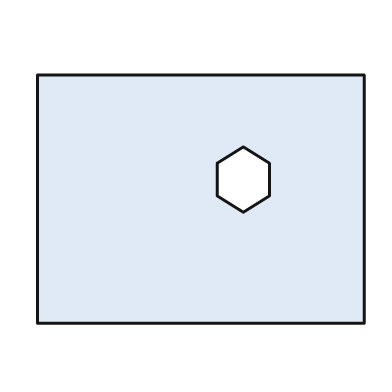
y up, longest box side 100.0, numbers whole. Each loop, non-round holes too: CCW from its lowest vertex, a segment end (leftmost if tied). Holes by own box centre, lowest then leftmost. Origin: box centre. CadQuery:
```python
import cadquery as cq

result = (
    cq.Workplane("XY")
    .moveTo(-50.0, -38.0)
    .lineTo(50.0, -38.0)
    .lineTo(50.0, 38.0)
    .lineTo(-50.0, 38.0)
    .close()
    .moveTo(13.0, -4.0)
    .lineTo(21.0, 1.0)
    .lineTo(21.0, 11.0)
    .lineTo(13.0, 16.0)
    .lineTo(5.0, 11.0)
    .lineTo(5.0, 1.0)
    .close()
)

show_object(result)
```